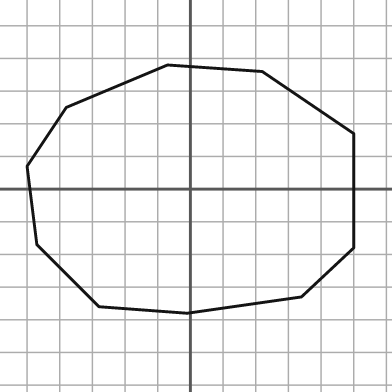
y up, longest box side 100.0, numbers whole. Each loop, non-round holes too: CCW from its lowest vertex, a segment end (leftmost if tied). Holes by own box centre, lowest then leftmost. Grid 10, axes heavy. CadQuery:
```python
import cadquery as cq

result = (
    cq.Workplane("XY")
    .moveTo(-1.0, -38.0)
    .lineTo(34.0, -33.0)
    .lineTo(50.0, -18.0)
    .lineTo(50.0, 17.0)
    .lineTo(22.0, 36.0)
    .lineTo(-7.0, 38.0)
    .lineTo(-38.0, 25.0)
    .lineTo(-50.0, 7.0)
    .lineTo(-47.0, -17.0)
    .lineTo(-28.0, -36.0)
    .close()
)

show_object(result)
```